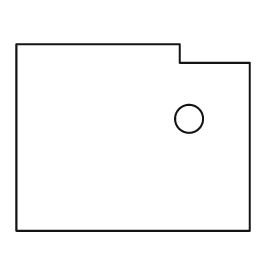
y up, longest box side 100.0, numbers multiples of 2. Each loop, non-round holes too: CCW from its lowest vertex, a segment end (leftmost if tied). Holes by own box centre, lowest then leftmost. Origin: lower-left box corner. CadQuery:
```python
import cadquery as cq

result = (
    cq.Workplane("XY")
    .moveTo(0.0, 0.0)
    .lineTo(100.0, 0.0)
    .lineTo(100.0, 72.0)
    .lineTo(70.0, 72.0)
    .lineTo(70.0, 80.0)
    .lineTo(0.0, 80.0)
    .close()
    .moveTo(74.0, 48.0)
    .circle(6.0)
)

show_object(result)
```